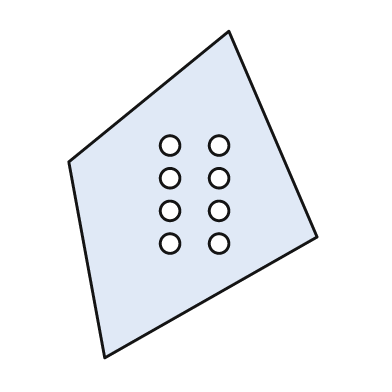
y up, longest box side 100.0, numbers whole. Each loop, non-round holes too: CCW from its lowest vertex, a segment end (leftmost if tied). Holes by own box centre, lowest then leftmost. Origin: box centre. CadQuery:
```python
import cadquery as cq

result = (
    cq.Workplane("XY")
    .moveTo(-27.0, -50.0)
    .lineTo(38.0, -13.0)
    .lineTo(11.0, 50.0)
    .lineTo(-38.0, 10.0)
    .close()
    .moveTo(-7.0, -15.0)
    .circle(3.0)
    .moveTo(8.0, -15.0)
    .circle(3.0)
    .moveTo(-7.0, -5.0)
    .circle(3.0)
    .moveTo(8.0, -5.0)
    .circle(3.0)
    .moveTo(-7.0, 5.0)
    .circle(3.0)
    .moveTo(8.0, 5.0)
    .circle(3.0)
    .moveTo(-7.0, 15.0)
    .circle(3.0)
    .moveTo(8.0, 15.0)
    .circle(3.0)
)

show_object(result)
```